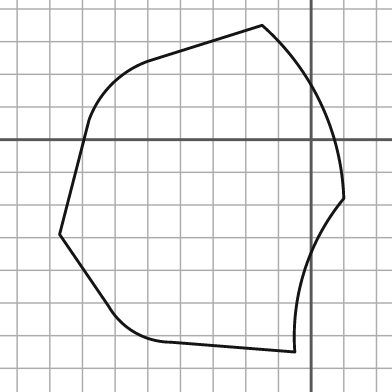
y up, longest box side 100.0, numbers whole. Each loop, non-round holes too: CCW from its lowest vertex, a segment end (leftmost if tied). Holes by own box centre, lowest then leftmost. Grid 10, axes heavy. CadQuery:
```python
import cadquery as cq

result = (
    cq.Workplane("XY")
    .moveTo(-5.0, -65.0)
    .threePointArc((-2.0, -40.0), (10.0, -18.0))
    .threePointArc((3.0, 11.0), (-15.0, 35.0))
    .lineTo(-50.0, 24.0)
    .threePointArc((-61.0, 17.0), (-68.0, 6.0))
    .lineTo(-77.0, -29.0)
    .lineTo(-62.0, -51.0)
    .threePointArc((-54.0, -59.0), (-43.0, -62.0))
    .close()
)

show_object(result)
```